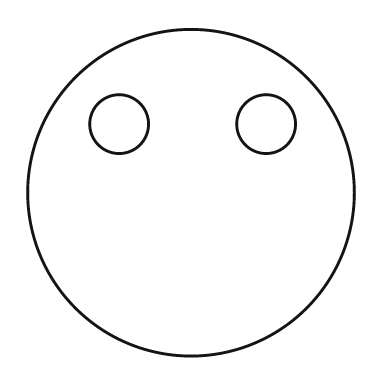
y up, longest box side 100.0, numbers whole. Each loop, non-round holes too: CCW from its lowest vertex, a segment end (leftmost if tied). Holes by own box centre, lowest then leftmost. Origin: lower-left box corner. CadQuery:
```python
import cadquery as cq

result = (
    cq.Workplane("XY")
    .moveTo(50.0, 50.0)
    .circle(50.0)
    .moveTo(28.0, 71.0)
    .circle(9.0)
    .moveTo(73.0, 71.0)
    .circle(9.0)
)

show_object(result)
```